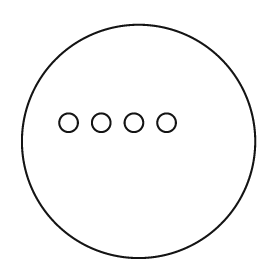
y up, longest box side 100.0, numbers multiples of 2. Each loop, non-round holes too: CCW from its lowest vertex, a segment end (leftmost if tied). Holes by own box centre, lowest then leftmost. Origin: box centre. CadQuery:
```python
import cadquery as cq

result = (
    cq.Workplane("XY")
    .moveTo(0.0, 0.0)
    .circle(50.0)
    .moveTo(-30.0, 8.0)
    .circle(4.0)
    .moveTo(-16.0, 8.0)
    .circle(4.0)
    .moveTo(-2.0, 8.0)
    .circle(4.0)
    .moveTo(12.0, 8.0)
    .circle(4.0)
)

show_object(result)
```